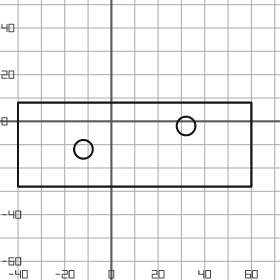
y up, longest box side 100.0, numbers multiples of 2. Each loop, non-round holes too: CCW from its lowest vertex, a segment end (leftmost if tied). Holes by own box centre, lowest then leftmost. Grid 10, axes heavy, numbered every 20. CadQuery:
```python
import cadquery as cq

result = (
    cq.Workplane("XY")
    .moveTo(-40.0, -28.0)
    .lineTo(60.0, -28.0)
    .lineTo(60.0, 8.0)
    .lineTo(-40.0, 8.0)
    .close()
    .moveTo(-12.0, -12.0)
    .circle(4.0)
    .moveTo(32.0, -2.0)
    .circle(4.0)
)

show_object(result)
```